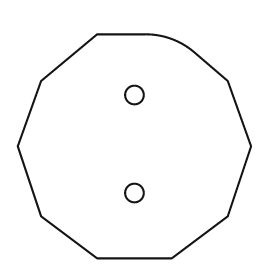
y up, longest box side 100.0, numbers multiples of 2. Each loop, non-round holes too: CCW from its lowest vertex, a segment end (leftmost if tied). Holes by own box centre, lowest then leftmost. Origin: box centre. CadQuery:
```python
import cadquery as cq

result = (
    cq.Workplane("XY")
    .moveTo(-16.0, -48.0)
    .lineTo(16.0, -48.0)
    .lineTo(40.0, -30.0)
    .lineTo(50.0, 0.0)
    .lineTo(40.0, 28.0)
    .lineTo(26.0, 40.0)
    .threePointArc((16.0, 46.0), (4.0, 48.0))
    .lineTo(-16.0, 48.0)
    .lineTo(-40.0, 28.0)
    .lineTo(-50.0, 0.0)
    .lineTo(-40.0, -30.0)
    .close()
    .moveTo(0.0, -20.0)
    .circle(4.0)
    .moveTo(0.0, 22.0)
    .circle(4.0)
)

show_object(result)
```